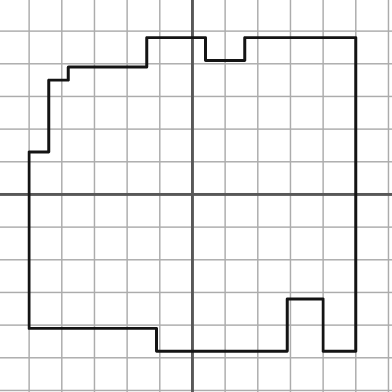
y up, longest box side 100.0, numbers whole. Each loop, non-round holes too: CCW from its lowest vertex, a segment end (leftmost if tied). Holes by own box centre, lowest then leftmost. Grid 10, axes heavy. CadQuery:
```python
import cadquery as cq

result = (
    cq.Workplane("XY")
    .moveTo(-11.0, -48.0)
    .lineTo(29.0, -48.0)
    .lineTo(29.0, -32.0)
    .lineTo(40.0, -32.0)
    .lineTo(40.0, -48.0)
    .lineTo(50.0, -48.0)
    .lineTo(50.0, 48.0)
    .lineTo(16.0, 48.0)
    .lineTo(16.0, 41.0)
    .lineTo(4.0, 41.0)
    .lineTo(4.0, 48.0)
    .lineTo(-14.0, 48.0)
    .lineTo(-14.0, 39.0)
    .lineTo(-38.0, 39.0)
    .lineTo(-38.0, 35.0)
    .lineTo(-44.0, 35.0)
    .lineTo(-44.0, 13.0)
    .lineTo(-50.0, 13.0)
    .lineTo(-50.0, -41.0)
    .lineTo(-11.0, -41.0)
    .close()
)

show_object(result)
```